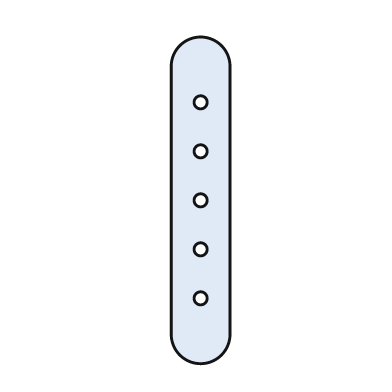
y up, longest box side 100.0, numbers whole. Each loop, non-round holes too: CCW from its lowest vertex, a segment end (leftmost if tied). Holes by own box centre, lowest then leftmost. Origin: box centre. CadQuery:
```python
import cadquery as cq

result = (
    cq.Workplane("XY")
    .moveTo(-9.0, -41.0)
    .threePointArc((0.0, -50.0), (9.0, -41.0))
    .lineTo(9.0, 41.0)
    .threePointArc((0.0, 50.0), (-9.0, 41.0))
    .close()
    .moveTo(0.0, -30.0)
    .circle(2.0)
    .moveTo(0.0, -15.0)
    .circle(2.0)
    .moveTo(0.0, 0.0)
    .circle(2.0)
    .moveTo(0.0, 15.0)
    .circle(2.0)
    .moveTo(0.0, 30.0)
    .circle(2.0)
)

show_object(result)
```